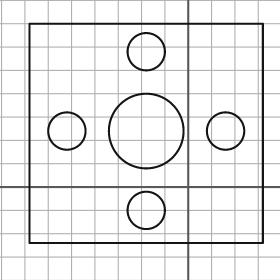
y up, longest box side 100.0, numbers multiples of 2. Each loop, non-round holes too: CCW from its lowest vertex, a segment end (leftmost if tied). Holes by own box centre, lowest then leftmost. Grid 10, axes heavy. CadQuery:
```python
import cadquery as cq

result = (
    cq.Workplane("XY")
    .moveTo(-68.0, -24.0)
    .lineTo(32.0, -24.0)
    .lineTo(32.0, 70.0)
    .lineTo(-68.0, 70.0)
    .close()
    .moveTo(-18.0, -10.0)
    .circle(8.0)
    .moveTo(-52.0, 24.0)
    .circle(8.0)
    .moveTo(-18.0, 24.0)
    .circle(16.0)
    .moveTo(16.0, 24.0)
    .circle(8.0)
    .moveTo(-18.0, 58.0)
    .circle(8.0)
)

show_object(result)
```